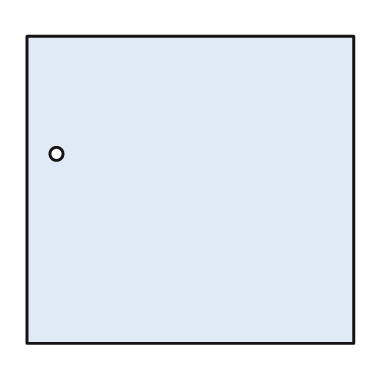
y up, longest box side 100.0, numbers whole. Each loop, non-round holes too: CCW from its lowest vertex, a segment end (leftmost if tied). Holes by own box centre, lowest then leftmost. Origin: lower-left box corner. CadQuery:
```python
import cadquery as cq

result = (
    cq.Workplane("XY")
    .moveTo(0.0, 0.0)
    .lineTo(100.0, 0.0)
    .lineTo(100.0, 94.0)
    .lineTo(0.0, 94.0)
    .close()
    .moveTo(9.0, 58.0)
    .circle(2.0)
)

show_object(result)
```